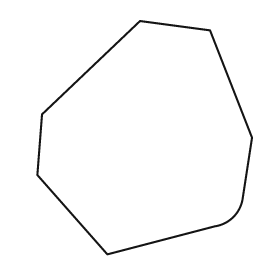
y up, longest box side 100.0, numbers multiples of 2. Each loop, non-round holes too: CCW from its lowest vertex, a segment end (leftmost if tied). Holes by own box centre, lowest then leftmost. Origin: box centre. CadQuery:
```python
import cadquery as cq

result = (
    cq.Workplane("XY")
    .moveTo(-16.0, -50.0)
    .lineTo(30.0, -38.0)
    .threePointArc((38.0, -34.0), (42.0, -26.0))
    .lineTo(46.0, 0.0)
    .lineTo(28.0, 46.0)
    .lineTo(-2.0, 50.0)
    .lineTo(-44.0, 10.0)
    .lineTo(-46.0, -16.0)
    .close()
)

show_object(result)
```